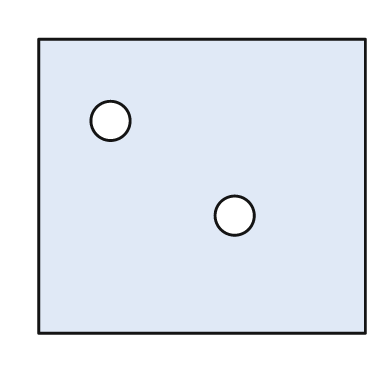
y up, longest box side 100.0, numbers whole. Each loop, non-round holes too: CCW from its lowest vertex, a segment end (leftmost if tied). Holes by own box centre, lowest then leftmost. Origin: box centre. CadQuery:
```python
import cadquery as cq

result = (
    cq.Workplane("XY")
    .moveTo(-50.0, -45.0)
    .lineTo(50.0, -45.0)
    .lineTo(50.0, 45.0)
    .lineTo(-50.0, 45.0)
    .close()
    .moveTo(10.0, -9.0)
    .circle(6.0)
    .moveTo(-28.0, 20.0)
    .circle(6.0)
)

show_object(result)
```